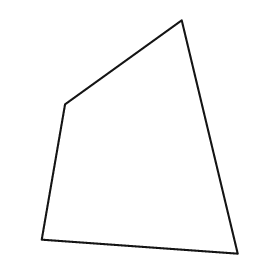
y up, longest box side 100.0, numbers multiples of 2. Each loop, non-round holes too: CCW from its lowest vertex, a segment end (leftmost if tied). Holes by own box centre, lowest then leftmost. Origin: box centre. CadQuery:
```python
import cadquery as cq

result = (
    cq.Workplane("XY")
    .moveTo(42.0, -50.0)
    .lineTo(18.0, 50.0)
    .lineTo(-32.0, 14.0)
    .lineTo(-42.0, -44.0)
    .close()
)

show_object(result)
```